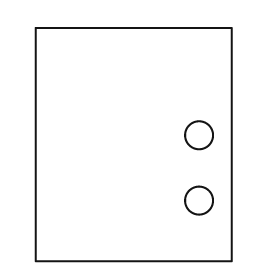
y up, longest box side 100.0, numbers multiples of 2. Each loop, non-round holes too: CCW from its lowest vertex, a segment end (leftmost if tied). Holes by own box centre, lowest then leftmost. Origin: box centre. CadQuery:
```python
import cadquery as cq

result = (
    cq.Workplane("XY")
    .moveTo(-42.0, -50.0)
    .lineTo(42.0, -50.0)
    .lineTo(42.0, 50.0)
    .lineTo(-42.0, 50.0)
    .close()
    .moveTo(28.0, -24.0)
    .circle(6.0)
    .moveTo(28.0, 4.0)
    .circle(6.0)
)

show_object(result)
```